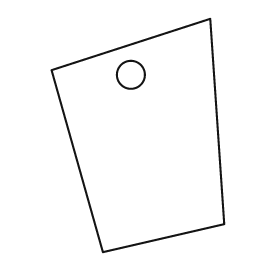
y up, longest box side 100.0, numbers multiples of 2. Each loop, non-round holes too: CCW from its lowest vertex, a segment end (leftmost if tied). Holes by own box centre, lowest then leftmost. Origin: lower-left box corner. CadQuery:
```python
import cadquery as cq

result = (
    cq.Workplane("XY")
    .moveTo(22.0, 0.0)
    .lineTo(74.0, 12.0)
    .lineTo(68.0, 100.0)
    .lineTo(0.0, 78.0)
    .close()
    .moveTo(34.0, 76.0)
    .circle(6.0)
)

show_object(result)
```